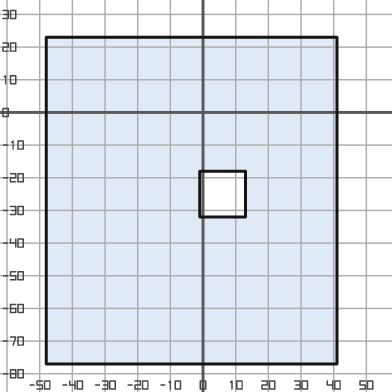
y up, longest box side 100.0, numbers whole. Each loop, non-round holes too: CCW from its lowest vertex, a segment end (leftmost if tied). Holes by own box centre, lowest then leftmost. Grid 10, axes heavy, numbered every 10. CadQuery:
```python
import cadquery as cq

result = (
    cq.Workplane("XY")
    .moveTo(-48.0, -77.0)
    .lineTo(41.0, -77.0)
    .lineTo(41.0, 23.0)
    .lineTo(-48.0, 23.0)
    .close()
    .moveTo(-1.0, -32.0)
    .lineTo(13.0, -32.0)
    .lineTo(13.0, -18.0)
    .lineTo(-1.0, -18.0)
    .close()
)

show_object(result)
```